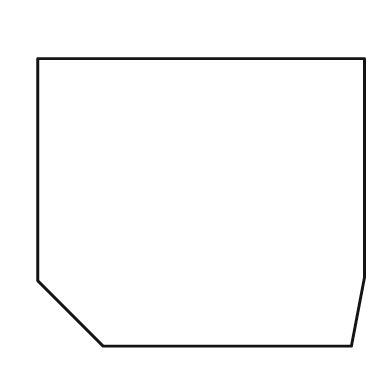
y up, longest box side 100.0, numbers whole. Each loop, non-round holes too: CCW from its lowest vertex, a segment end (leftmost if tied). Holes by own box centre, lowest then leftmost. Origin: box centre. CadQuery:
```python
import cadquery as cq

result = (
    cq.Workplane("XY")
    .moveTo(-30.0, -44.0)
    .lineTo(46.0, -44.0)
    .lineTo(50.0, -23.0)
    .lineTo(50.0, 44.0)
    .lineTo(-50.0, 44.0)
    .lineTo(-50.0, -24.0)
    .close()
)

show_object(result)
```